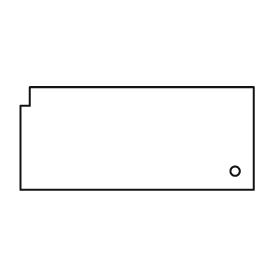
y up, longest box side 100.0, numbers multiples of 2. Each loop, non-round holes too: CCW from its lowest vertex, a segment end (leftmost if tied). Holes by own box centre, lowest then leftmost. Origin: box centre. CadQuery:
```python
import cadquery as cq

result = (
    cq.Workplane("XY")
    .moveTo(-50.0, -22.0)
    .lineTo(50.0, -22.0)
    .lineTo(50.0, 22.0)
    .lineTo(-46.0, 22.0)
    .lineTo(-46.0, 14.0)
    .lineTo(-50.0, 14.0)
    .close()
    .moveTo(42.0, -14.0)
    .circle(2.0)
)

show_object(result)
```